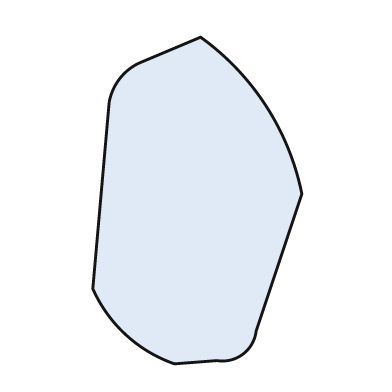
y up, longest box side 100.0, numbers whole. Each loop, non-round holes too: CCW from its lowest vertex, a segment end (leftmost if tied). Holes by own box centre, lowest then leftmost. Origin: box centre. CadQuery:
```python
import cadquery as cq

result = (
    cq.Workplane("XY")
    .moveTo(-7.0, -50.0)
    .lineTo(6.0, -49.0)
    .threePointArc((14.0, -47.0), (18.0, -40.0))
    .lineTo(32.0, 2.0)
    .threePointArc((21.0, 29.0), (1.0, 50.0))
    .lineTo(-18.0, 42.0)
    .threePointArc((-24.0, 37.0), (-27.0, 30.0))
    .lineTo(-32.0, -27.0)
    .threePointArc((-22.0, -41.0), (-7.0, -50.0))
    .close()
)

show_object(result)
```